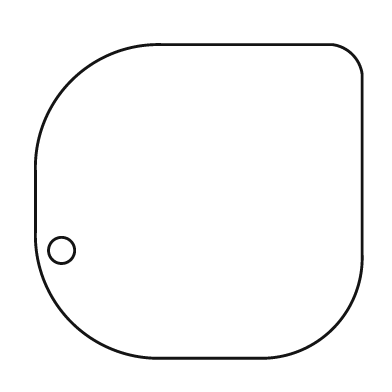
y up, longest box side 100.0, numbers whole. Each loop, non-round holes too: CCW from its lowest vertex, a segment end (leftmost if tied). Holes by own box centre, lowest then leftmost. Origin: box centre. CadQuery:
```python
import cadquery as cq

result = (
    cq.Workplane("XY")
    .moveTo(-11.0, -48.0)
    .lineTo(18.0, -48.0)
    .threePointArc((41.0, -39.0), (50.0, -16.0))
    .lineTo(50.0, 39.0)
    .threePointArc((47.0, 45.0), (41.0, 48.0))
    .lineTo(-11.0, 48.0)
    .threePointArc((-39.0, 37.0), (-50.0, 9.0))
    .lineTo(-50.0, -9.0)
    .threePointArc((-39.0, -37.0), (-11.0, -48.0))
    .close()
    .moveTo(-42.0, -15.0)
    .circle(4.0)
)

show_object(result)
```